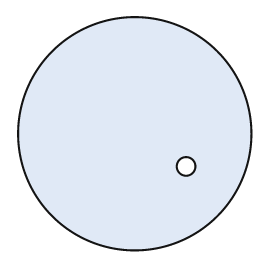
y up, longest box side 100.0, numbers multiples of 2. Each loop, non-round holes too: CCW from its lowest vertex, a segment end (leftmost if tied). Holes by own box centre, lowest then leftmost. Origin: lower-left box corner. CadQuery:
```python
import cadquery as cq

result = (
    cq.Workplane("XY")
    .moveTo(50.0, 50.0)
    .circle(50.0)
    .moveTo(72.0, 36.0)
    .circle(4.0)
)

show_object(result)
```